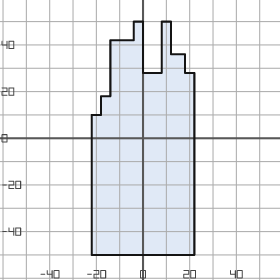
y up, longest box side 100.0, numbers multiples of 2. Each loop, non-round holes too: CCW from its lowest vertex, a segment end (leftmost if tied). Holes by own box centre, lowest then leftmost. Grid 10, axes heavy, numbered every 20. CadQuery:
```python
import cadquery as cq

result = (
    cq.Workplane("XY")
    .moveTo(-22.0, -50.0)
    .lineTo(22.0, -50.0)
    .lineTo(22.0, 28.0)
    .lineTo(18.0, 28.0)
    .lineTo(18.0, 36.0)
    .lineTo(12.0, 36.0)
    .lineTo(12.0, 50.0)
    .lineTo(8.0, 50.0)
    .lineTo(8.0, 28.0)
    .lineTo(0.0, 28.0)
    .lineTo(0.0, 50.0)
    .lineTo(-4.0, 50.0)
    .lineTo(-4.0, 42.0)
    .lineTo(-14.0, 42.0)
    .lineTo(-14.0, 18.0)
    .lineTo(-18.0, 18.0)
    .lineTo(-18.0, 10.0)
    .lineTo(-22.0, 10.0)
    .close()
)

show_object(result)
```